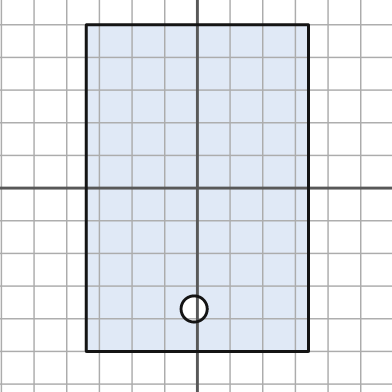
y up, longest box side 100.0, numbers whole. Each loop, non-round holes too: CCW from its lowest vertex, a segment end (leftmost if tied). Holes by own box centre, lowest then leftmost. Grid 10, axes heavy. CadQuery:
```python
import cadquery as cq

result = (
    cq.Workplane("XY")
    .moveTo(-34.0, -50.0)
    .lineTo(34.0, -50.0)
    .lineTo(34.0, 50.0)
    .lineTo(-34.0, 50.0)
    .close()
    .moveTo(-1.0, -37.0)
    .circle(4.0)
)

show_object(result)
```